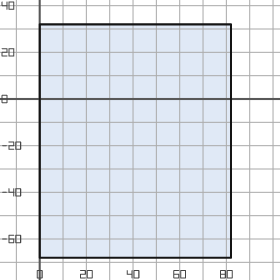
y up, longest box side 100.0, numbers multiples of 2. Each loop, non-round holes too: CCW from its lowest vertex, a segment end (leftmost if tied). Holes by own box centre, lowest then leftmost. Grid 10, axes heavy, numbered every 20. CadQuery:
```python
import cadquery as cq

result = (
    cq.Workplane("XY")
    .moveTo(0.0, -68.0)
    .lineTo(82.0, -68.0)
    .lineTo(82.0, 32.0)
    .lineTo(0.0, 32.0)
    .close()
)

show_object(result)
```